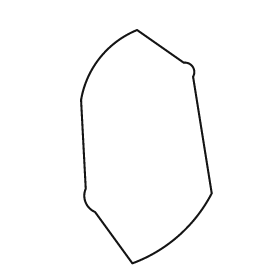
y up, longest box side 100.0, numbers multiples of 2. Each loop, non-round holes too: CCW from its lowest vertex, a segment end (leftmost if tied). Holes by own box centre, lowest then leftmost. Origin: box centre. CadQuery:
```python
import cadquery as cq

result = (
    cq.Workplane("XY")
    .moveTo(-6.0, -50.0)
    .threePointArc((14.0, -38.0), (28.0, -20.0))
    .lineTo(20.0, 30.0)
    .threePointArc((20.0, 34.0), (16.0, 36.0))
    .lineTo(-4.0, 50.0)
    .threePointArc((-20.0, 38.0), (-28.0, 20.0))
    .lineTo(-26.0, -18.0)
    .threePointArc((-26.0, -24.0), (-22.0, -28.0))
    .close()
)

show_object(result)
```